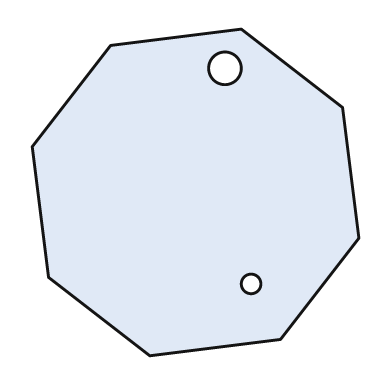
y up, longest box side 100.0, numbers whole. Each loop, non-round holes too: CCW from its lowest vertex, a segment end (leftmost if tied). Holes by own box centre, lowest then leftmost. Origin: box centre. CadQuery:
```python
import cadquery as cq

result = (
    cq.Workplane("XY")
    .moveTo(-14.0, -50.0)
    .lineTo(26.0, -45.0)
    .lineTo(50.0, -14.0)
    .lineTo(45.0, 26.0)
    .lineTo(14.0, 50.0)
    .lineTo(-26.0, 45.0)
    .lineTo(-50.0, 14.0)
    .lineTo(-45.0, -26.0)
    .close()
    .moveTo(17.0, -28.0)
    .circle(3.0)
    .moveTo(9.0, 38.0)
    .circle(5.0)
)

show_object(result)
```